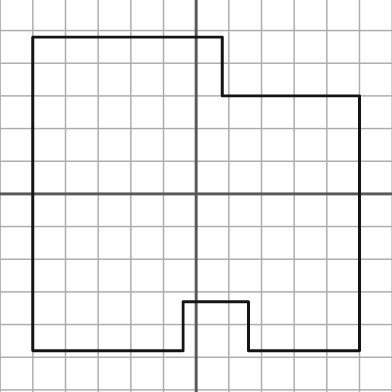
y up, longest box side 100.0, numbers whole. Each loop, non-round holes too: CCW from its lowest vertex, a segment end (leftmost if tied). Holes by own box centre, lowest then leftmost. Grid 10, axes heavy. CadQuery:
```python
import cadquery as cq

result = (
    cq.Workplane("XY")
    .moveTo(-50.0, -48.0)
    .lineTo(-4.0, -48.0)
    .lineTo(-4.0, -33.0)
    .lineTo(16.0, -33.0)
    .lineTo(16.0, -48.0)
    .lineTo(50.0, -48.0)
    .lineTo(50.0, 30.0)
    .lineTo(8.0, 30.0)
    .lineTo(8.0, 48.0)
    .lineTo(-50.0, 48.0)
    .close()
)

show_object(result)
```